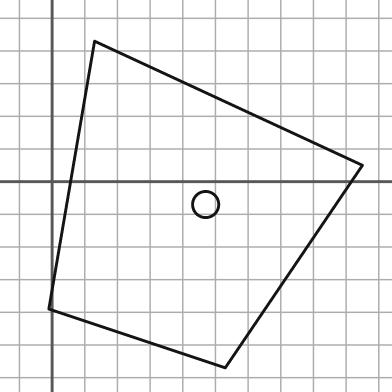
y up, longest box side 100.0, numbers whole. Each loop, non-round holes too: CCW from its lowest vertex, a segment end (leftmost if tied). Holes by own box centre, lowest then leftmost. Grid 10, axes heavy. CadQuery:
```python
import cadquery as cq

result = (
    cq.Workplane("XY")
    .moveTo(53.0, -57.0)
    .lineTo(95.0, 5.0)
    .lineTo(13.0, 43.0)
    .lineTo(-1.0, -39.0)
    .close()
    .moveTo(47.0, -7.0)
    .circle(4.0)
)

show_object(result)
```